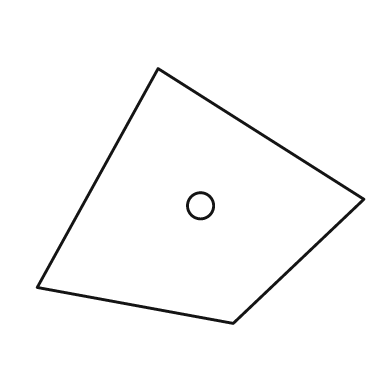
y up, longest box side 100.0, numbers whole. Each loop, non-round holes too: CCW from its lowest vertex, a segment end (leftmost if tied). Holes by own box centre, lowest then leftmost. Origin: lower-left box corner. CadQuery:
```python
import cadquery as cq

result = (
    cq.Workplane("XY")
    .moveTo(60.0, 0.0)
    .lineTo(100.0, 38.0)
    .lineTo(37.0, 78.0)
    .lineTo(0.0, 11.0)
    .close()
    .moveTo(50.0, 36.0)
    .circle(4.0)
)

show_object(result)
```